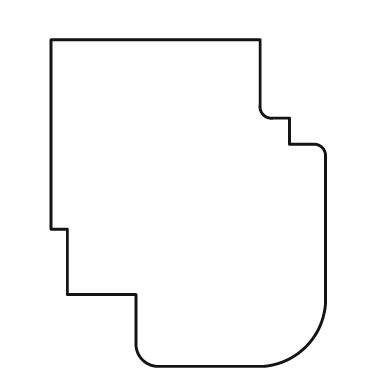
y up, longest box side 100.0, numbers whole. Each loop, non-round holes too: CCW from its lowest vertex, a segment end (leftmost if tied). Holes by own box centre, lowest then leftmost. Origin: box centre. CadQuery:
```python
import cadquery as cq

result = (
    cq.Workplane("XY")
    .moveTo(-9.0, -50.0)
    .lineTo(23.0, -50.0)
    .threePointArc((36.0, -44.0), (42.0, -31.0))
    .lineTo(42.0, 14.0)
    .threePointArc((41.0, 17.0), (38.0, 18.0))
    .lineTo(31.0, 18.0)
    .lineTo(31.0, 26.0)
    .lineTo(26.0, 26.0)
    .threePointArc((23.0, 27.0), (22.0, 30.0))
    .lineTo(22.0, 50.0)
    .lineTo(-42.0, 50.0)
    .lineTo(-42.0, -8.0)
    .lineTo(-37.0, -8.0)
    .lineTo(-37.0, -28.0)
    .lineTo(-16.0, -28.0)
    .lineTo(-16.0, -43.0)
    .threePointArc((-14.0, -48.0), (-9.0, -50.0))
    .close()
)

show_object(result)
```